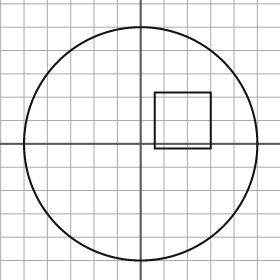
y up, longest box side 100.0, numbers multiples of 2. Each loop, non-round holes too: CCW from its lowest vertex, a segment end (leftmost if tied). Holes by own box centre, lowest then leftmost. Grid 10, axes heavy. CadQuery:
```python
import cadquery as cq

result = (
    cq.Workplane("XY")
    .moveTo(0.0, 0.0)
    .circle(50.0)
    .moveTo(6.0, -2.0)
    .lineTo(30.0, -2.0)
    .lineTo(30.0, 22.0)
    .lineTo(6.0, 22.0)
    .close()
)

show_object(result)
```